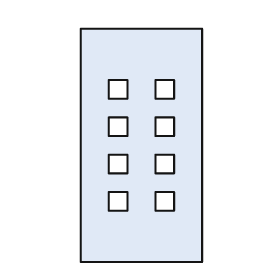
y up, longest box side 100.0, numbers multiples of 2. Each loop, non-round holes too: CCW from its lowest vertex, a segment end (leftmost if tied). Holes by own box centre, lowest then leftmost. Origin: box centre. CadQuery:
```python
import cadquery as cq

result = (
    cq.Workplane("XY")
    .moveTo(-26.0, -50.0)
    .lineTo(26.0, -50.0)
    .lineTo(26.0, 50.0)
    .lineTo(-26.0, 50.0)
    .close()
    .moveTo(-14.0, -28.0)
    .lineTo(-6.0, -28.0)
    .lineTo(-6.0, -20.0)
    .lineTo(-14.0, -20.0)
    .close()
    .moveTo(6.0, -28.0)
    .lineTo(14.0, -28.0)
    .lineTo(14.0, -20.0)
    .lineTo(6.0, -20.0)
    .close()
    .moveTo(-14.0, -12.0)
    .lineTo(-6.0, -12.0)
    .lineTo(-6.0, -4.0)
    .lineTo(-14.0, -4.0)
    .close()
    .moveTo(6.0, -12.0)
    .lineTo(14.0, -12.0)
    .lineTo(14.0, -4.0)
    .lineTo(6.0, -4.0)
    .close()
    .moveTo(-14.0, 4.0)
    .lineTo(-6.0, 4.0)
    .lineTo(-6.0, 12.0)
    .lineTo(-14.0, 12.0)
    .close()
    .moveTo(6.0, 4.0)
    .lineTo(14.0, 4.0)
    .lineTo(14.0, 12.0)
    .lineTo(6.0, 12.0)
    .close()
    .moveTo(-14.0, 20.0)
    .lineTo(-6.0, 20.0)
    .lineTo(-6.0, 28.0)
    .lineTo(-14.0, 28.0)
    .close()
    .moveTo(6.0, 20.0)
    .lineTo(14.0, 20.0)
    .lineTo(14.0, 28.0)
    .lineTo(6.0, 28.0)
    .close()
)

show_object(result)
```